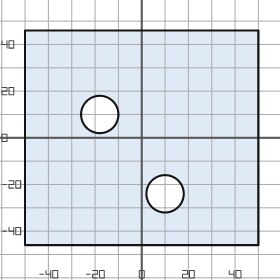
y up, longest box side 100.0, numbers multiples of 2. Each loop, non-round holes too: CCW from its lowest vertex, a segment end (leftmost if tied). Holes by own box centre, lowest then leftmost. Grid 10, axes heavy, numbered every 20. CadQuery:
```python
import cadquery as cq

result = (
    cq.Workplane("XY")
    .moveTo(-50.0, -46.0)
    .lineTo(50.0, -46.0)
    .lineTo(50.0, 46.0)
    .lineTo(-50.0, 46.0)
    .close()
    .moveTo(10.0, -24.0)
    .circle(8.0)
    .moveTo(-18.0, 10.0)
    .circle(8.0)
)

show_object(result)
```